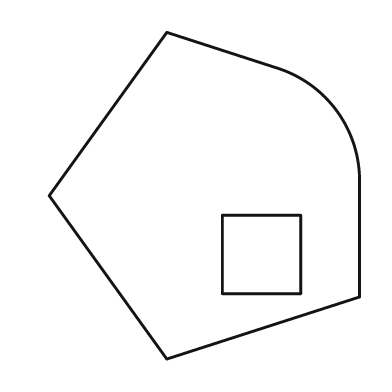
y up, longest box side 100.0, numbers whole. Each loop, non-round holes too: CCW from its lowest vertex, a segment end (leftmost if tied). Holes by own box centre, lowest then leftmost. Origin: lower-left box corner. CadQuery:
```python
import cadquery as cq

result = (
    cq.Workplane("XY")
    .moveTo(36.0, 0.0)
    .lineTo(95.0, 19.0)
    .lineTo(95.0, 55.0)
    .threePointArc((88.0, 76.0), (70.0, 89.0))
    .lineTo(36.0, 100.0)
    .lineTo(0.0, 50.0)
    .close()
    .moveTo(53.0, 20.0)
    .lineTo(77.0, 20.0)
    .lineTo(77.0, 44.0)
    .lineTo(53.0, 44.0)
    .close()
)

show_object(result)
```